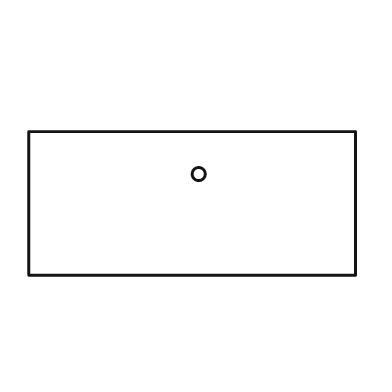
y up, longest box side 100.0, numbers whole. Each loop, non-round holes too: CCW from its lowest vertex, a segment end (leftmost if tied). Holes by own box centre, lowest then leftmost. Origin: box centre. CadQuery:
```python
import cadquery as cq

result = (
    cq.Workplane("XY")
    .moveTo(-50.0, -22.0)
    .lineTo(50.0, -22.0)
    .lineTo(50.0, 22.0)
    .lineTo(-50.0, 22.0)
    .close()
    .moveTo(2.0, 9.0)
    .circle(2.0)
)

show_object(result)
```